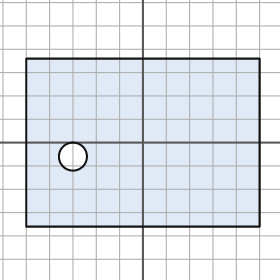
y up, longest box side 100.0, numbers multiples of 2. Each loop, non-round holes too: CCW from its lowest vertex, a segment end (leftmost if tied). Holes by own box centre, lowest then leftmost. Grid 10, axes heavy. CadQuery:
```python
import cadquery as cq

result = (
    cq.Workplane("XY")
    .moveTo(-50.0, -36.0)
    .lineTo(50.0, -36.0)
    .lineTo(50.0, 36.0)
    .lineTo(-50.0, 36.0)
    .close()
    .moveTo(-30.0, -6.0)
    .circle(6.0)
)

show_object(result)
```